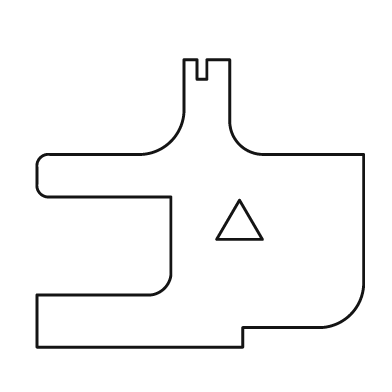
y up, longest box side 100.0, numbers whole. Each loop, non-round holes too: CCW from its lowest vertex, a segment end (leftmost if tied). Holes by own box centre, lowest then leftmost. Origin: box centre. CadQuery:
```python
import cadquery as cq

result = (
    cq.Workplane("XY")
    .moveTo(-50.0, -44.0)
    .lineTo(13.0, -44.0)
    .lineTo(13.0, -38.0)
    .lineTo(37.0, -38.0)
    .threePointArc((46.0, -34.0), (50.0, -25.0))
    .lineTo(50.0, 15.0)
    .lineTo(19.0, 15.0)
    .threePointArc((12.0, 18.0), (9.0, 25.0))
    .lineTo(9.0, 44.0)
    .lineTo(2.0, 44.0)
    .lineTo(2.0, 38.0)
    .lineTo(-1.0, 38.0)
    .lineTo(-1.0, 44.0)
    .lineTo(-5.0, 44.0)
    .lineTo(-5.0, 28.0)
    .threePointArc((-9.0, 19.0), (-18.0, 15.0))
    .lineTo(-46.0, 15.0)
    .threePointArc((-49.0, 14.0), (-50.0, 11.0))
    .lineTo(-50.0, 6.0)
    .threePointArc((-49.0, 3.0), (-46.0, 2.0))
    .lineTo(-9.0, 2.0)
    .lineTo(-9.0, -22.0)
    .threePointArc((-11.0, -26.0), (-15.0, -28.0))
    .lineTo(-50.0, -28.0)
    .close()
    .moveTo(5.0, -11.0)
    .lineTo(19.0, -11.0)
    .lineTo(12.0, 1.0)
    .close()
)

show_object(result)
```